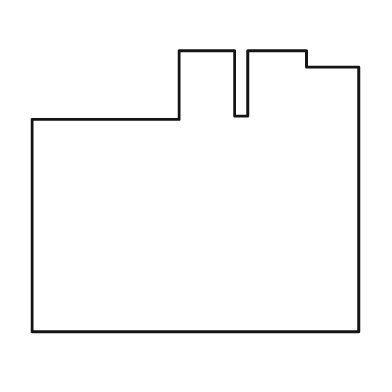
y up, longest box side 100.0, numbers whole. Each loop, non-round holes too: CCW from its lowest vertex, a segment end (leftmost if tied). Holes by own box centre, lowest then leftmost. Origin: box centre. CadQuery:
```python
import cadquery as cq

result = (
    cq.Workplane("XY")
    .moveTo(-50.0, -43.0)
    .lineTo(50.0, -43.0)
    .lineTo(50.0, 38.0)
    .lineTo(34.0, 38.0)
    .lineTo(34.0, 43.0)
    .lineTo(16.0, 43.0)
    .lineTo(16.0, 23.0)
    .lineTo(12.0, 23.0)
    .lineTo(12.0, 43.0)
    .lineTo(-5.0, 43.0)
    .lineTo(-5.0, 22.0)
    .lineTo(-50.0, 22.0)
    .close()
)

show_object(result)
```